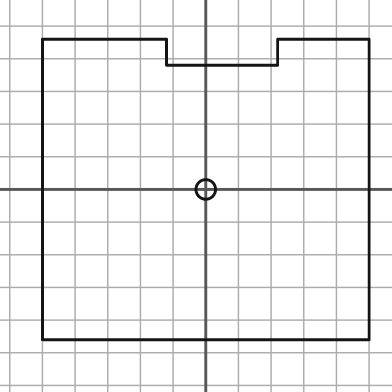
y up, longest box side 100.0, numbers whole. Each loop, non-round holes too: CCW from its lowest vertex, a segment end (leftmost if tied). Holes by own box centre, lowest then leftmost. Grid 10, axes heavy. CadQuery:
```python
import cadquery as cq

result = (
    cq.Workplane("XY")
    .moveTo(-50.0, -46.0)
    .lineTo(50.0, -46.0)
    .lineTo(50.0, 46.0)
    .lineTo(22.0, 46.0)
    .lineTo(22.0, 38.0)
    .lineTo(-12.0, 38.0)
    .lineTo(-12.0, 46.0)
    .lineTo(-50.0, 46.0)
    .close()
    .moveTo(0.0, 0.0)
    .circle(3.0)
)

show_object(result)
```